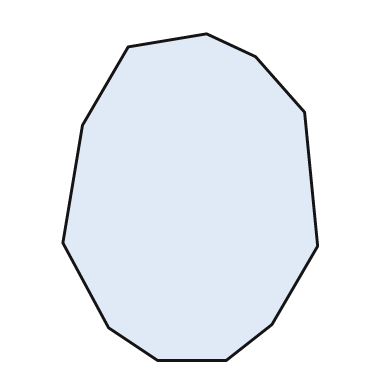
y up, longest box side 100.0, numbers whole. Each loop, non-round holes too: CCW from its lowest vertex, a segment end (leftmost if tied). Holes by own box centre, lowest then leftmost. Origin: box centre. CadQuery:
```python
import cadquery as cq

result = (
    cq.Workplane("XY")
    .moveTo(-10.0, -50.0)
    .lineTo(11.0, -50.0)
    .lineTo(25.0, -39.0)
    .lineTo(39.0, -15.0)
    .lineTo(35.0, 26.0)
    .lineTo(20.0, 43.0)
    .lineTo(5.0, 50.0)
    .lineTo(-19.0, 46.0)
    .lineTo(-33.0, 22.0)
    .lineTo(-39.0, -14.0)
    .lineTo(-25.0, -40.0)
    .close()
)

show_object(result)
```